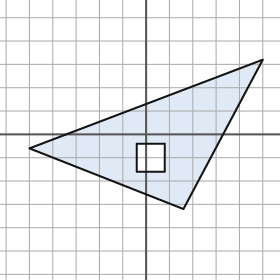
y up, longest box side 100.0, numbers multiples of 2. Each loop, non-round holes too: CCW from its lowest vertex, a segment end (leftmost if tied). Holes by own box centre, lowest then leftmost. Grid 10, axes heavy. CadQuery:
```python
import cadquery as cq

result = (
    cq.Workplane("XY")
    .moveTo(16.0, -32.0)
    .lineTo(50.0, 32.0)
    .lineTo(-50.0, -6.0)
    .close()
    .moveTo(-4.0, -16.0)
    .lineTo(8.0, -16.0)
    .lineTo(8.0, -4.0)
    .lineTo(-4.0, -4.0)
    .close()
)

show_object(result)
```